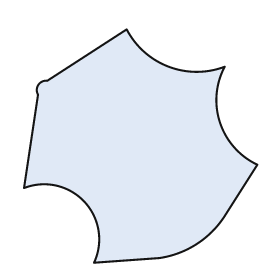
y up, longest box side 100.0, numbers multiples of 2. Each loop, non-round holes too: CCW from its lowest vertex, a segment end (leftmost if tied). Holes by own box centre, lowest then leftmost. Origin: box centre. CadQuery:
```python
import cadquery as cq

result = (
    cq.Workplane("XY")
    .moveTo(-20.0, -50.0)
    .lineTo(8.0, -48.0)
    .threePointArc((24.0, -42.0), (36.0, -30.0))
    .lineTo(50.0, -8.0)
    .threePointArc((34.0, 10.0), (36.0, 34.0))
    .threePointArc((12.0, 34.0), (-6.0, 50.0))
    .lineTo(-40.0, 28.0)
    .threePointArc((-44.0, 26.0), (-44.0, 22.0))
    .lineTo(-50.0, -18.0)
    .threePointArc((-24.0, -24.0), (-20.0, -50.0))
    .close()
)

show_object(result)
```